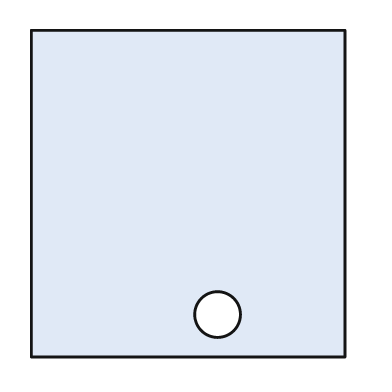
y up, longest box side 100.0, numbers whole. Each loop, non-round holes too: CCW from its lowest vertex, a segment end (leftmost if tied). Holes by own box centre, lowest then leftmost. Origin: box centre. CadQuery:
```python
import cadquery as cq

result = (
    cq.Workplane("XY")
    .moveTo(-48.0, -50.0)
    .lineTo(48.0, -50.0)
    .lineTo(48.0, 50.0)
    .lineTo(-48.0, 50.0)
    .close()
    .moveTo(9.0, -37.0)
    .circle(7.0)
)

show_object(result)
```